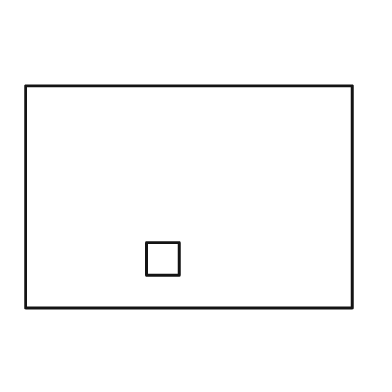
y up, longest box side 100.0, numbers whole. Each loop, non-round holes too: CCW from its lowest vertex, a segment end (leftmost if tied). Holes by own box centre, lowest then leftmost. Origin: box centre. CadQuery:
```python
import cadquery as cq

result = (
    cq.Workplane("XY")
    .moveTo(-50.0, -34.0)
    .lineTo(50.0, -34.0)
    .lineTo(50.0, 34.0)
    .lineTo(-50.0, 34.0)
    .close()
    .moveTo(-13.0, -24.0)
    .lineTo(-3.0, -24.0)
    .lineTo(-3.0, -14.0)
    .lineTo(-13.0, -14.0)
    .close()
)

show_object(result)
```